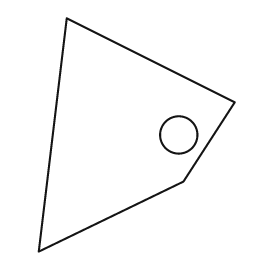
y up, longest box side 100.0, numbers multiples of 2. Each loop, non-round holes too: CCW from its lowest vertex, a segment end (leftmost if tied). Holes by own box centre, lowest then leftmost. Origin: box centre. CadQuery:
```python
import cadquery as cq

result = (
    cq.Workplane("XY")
    .moveTo(-42.0, -50.0)
    .lineTo(20.0, -20.0)
    .lineTo(42.0, 14.0)
    .lineTo(-30.0, 50.0)
    .close()
    .moveTo(18.0, 0.0)
    .circle(8.0)
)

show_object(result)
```